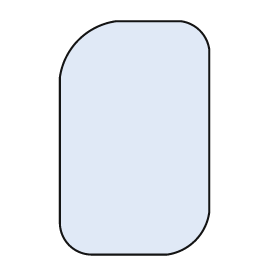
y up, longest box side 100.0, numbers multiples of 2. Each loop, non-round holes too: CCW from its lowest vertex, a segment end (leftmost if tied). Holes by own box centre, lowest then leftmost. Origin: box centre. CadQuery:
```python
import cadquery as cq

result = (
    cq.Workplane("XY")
    .moveTo(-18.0, -50.0)
    .lineTo(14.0, -50.0)
    .threePointArc((26.0, -44.0), (32.0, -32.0))
    .lineTo(32.0, 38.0)
    .threePointArc((28.0, 46.0), (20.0, 50.0))
    .lineTo(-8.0, 50.0)
    .threePointArc((-24.0, 42.0), (-32.0, 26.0))
    .lineTo(-32.0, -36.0)
    .threePointArc((-28.0, -46.0), (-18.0, -50.0))
    .close()
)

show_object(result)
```